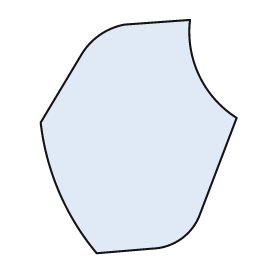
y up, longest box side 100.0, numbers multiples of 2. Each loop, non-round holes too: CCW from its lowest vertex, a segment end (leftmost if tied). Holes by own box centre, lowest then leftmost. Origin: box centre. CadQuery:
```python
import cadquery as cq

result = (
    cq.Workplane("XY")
    .moveTo(-18.0, -50.0)
    .lineTo(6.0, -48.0)
    .threePointArc((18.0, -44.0), (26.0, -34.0))
    .lineTo(42.0, 8.0)
    .threePointArc((26.0, 26.0), (22.0, 50.0))
    .lineTo(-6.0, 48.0)
    .threePointArc((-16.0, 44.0), (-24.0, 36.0))
    .lineTo(-42.0, 6.0)
    .threePointArc((-34.0, -24.0), (-18.0, -50.0))
    .close()
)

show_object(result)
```